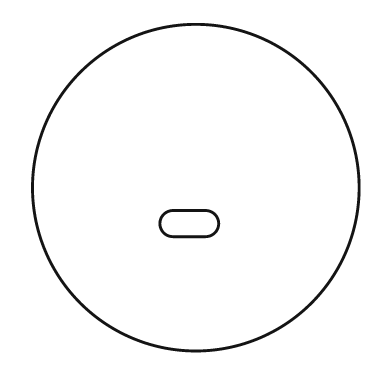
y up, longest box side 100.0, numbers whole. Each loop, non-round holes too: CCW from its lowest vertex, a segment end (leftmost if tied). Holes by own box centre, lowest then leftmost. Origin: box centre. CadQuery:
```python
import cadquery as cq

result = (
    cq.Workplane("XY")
    .moveTo(0.0, 0.0)
    .circle(50.0)
    .moveTo(-7.0, -15.0)
    .lineTo(3.0, -15.0)
    .threePointArc((7.0, -11.0), (3.0, -7.0))
    .lineTo(-7.0, -7.0)
    .threePointArc((-11.0, -11.0), (-7.0, -15.0))
    .close()
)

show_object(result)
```